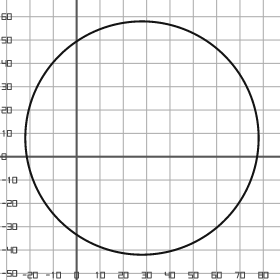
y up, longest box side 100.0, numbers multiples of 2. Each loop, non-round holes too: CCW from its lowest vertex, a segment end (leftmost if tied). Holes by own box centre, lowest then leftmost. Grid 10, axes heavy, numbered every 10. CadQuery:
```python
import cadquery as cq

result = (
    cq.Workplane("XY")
    .moveTo(28.0, 8.0)
    .circle(50.0)
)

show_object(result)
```